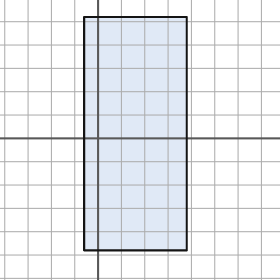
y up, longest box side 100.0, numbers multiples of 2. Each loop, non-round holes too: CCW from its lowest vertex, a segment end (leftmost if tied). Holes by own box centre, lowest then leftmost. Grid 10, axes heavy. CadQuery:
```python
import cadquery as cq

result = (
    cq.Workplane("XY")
    .moveTo(-6.0, -48.0)
    .lineTo(38.0, -48.0)
    .lineTo(38.0, 52.0)
    .lineTo(-6.0, 52.0)
    .close()
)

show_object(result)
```